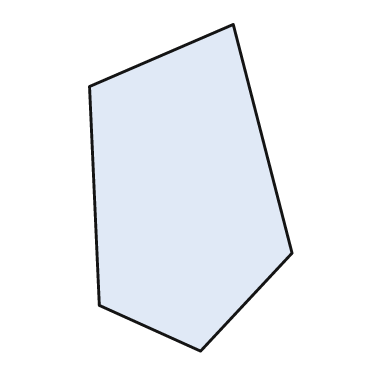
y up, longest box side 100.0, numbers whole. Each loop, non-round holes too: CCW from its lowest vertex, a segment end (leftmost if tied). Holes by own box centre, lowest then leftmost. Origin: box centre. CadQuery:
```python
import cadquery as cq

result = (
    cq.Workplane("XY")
    .moveTo(3.0, -50.0)
    .lineTo(31.0, -20.0)
    .lineTo(13.0, 50.0)
    .lineTo(-31.0, 31.0)
    .lineTo(-28.0, -36.0)
    .close()
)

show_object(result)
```